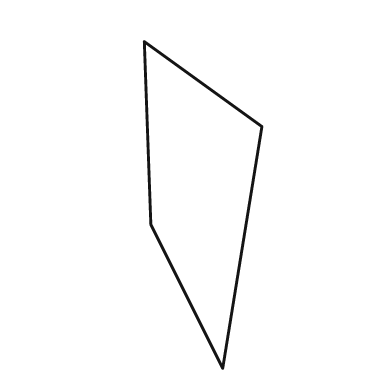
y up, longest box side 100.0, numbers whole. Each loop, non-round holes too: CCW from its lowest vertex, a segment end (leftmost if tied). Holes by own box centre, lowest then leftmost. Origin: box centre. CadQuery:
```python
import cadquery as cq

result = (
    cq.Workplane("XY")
    .moveTo(6.0, -50.0)
    .lineTo(18.0, 24.0)
    .lineTo(-18.0, 50.0)
    .lineTo(-16.0, -6.0)
    .close()
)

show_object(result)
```